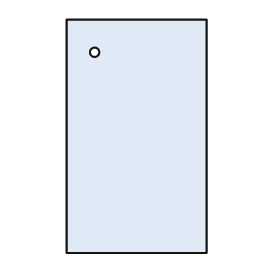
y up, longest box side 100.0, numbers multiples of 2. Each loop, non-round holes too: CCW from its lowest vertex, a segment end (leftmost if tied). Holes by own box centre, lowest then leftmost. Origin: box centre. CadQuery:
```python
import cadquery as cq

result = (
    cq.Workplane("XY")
    .moveTo(-30.0, -50.0)
    .lineTo(30.0, -50.0)
    .lineTo(30.0, 50.0)
    .lineTo(-30.0, 50.0)
    .close()
    .moveTo(-18.0, 36.0)
    .circle(2.0)
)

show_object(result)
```